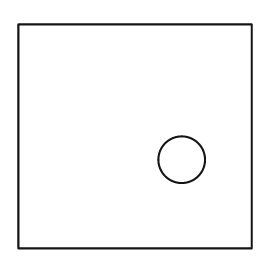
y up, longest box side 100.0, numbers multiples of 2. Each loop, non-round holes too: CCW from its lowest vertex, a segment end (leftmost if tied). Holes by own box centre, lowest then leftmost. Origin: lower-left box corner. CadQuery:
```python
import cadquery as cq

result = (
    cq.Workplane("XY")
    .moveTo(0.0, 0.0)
    .lineTo(100.0, 0.0)
    .lineTo(100.0, 96.0)
    .lineTo(0.0, 96.0)
    .close()
    .moveTo(70.0, 38.0)
    .circle(10.0)
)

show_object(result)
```